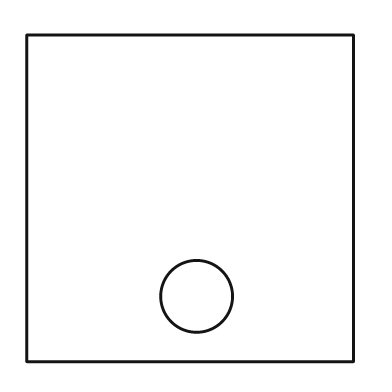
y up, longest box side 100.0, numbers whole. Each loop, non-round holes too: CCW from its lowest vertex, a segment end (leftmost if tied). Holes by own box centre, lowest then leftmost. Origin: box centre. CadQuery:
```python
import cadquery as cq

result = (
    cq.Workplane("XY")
    .moveTo(-50.0, -50.0)
    .lineTo(50.0, -50.0)
    .lineTo(50.0, 50.0)
    .lineTo(-50.0, 50.0)
    .close()
    .moveTo(2.0, -30.0)
    .circle(11.0)
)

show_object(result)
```